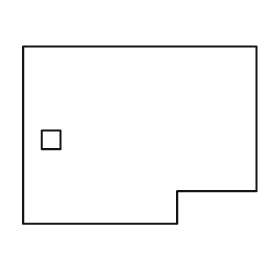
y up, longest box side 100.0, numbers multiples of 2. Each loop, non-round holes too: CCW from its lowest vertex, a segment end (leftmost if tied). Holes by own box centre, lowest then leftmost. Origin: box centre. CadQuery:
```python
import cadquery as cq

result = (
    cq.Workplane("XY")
    .moveTo(-50.0, -38.0)
    .lineTo(16.0, -38.0)
    .lineTo(16.0, -24.0)
    .lineTo(50.0, -24.0)
    .lineTo(50.0, 38.0)
    .lineTo(-50.0, 38.0)
    .close()
    .moveTo(-42.0, -6.0)
    .lineTo(-34.0, -6.0)
    .lineTo(-34.0, 2.0)
    .lineTo(-42.0, 2.0)
    .close()
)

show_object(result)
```